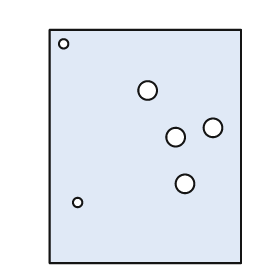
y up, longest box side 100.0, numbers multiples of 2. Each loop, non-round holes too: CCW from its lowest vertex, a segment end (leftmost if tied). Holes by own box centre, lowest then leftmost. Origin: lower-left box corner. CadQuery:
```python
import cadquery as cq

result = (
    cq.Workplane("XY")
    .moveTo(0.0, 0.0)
    .lineTo(82.0, 0.0)
    .lineTo(82.0, 100.0)
    .lineTo(0.0, 100.0)
    .close()
    .moveTo(12.0, 26.0)
    .circle(2.0)
    .moveTo(58.0, 34.0)
    .circle(4.0)
    .moveTo(54.0, 54.0)
    .circle(4.0)
    .moveTo(70.0, 58.0)
    .circle(4.0)
    .moveTo(42.0, 74.0)
    .circle(4.0)
    .moveTo(6.0, 94.0)
    .circle(2.0)
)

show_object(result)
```